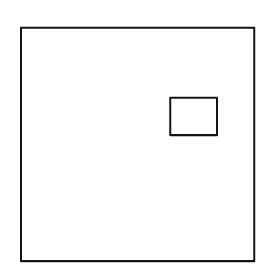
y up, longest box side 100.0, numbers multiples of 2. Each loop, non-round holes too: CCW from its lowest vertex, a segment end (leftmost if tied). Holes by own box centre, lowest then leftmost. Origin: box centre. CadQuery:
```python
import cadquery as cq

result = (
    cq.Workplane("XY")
    .moveTo(-50.0, -50.0)
    .lineTo(50.0, -50.0)
    .lineTo(50.0, 50.0)
    .lineTo(-50.0, 50.0)
    .close()
    .moveTo(14.0, 4.0)
    .lineTo(34.0, 4.0)
    .lineTo(34.0, 20.0)
    .lineTo(14.0, 20.0)
    .close()
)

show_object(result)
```